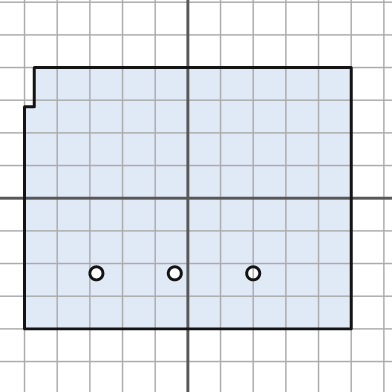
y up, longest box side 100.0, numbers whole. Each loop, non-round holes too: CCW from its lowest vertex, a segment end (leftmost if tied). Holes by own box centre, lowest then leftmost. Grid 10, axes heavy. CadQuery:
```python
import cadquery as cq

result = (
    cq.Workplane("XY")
    .moveTo(-50.0, -40.0)
    .lineTo(50.0, -40.0)
    .lineTo(50.0, 40.0)
    .lineTo(-47.0, 40.0)
    .lineTo(-47.0, 28.0)
    .lineTo(-50.0, 28.0)
    .close()
    .moveTo(-28.0, -23.0)
    .circle(2.0)
    .moveTo(-4.0, -23.0)
    .circle(2.0)
    .moveTo(20.0, -23.0)
    .circle(2.0)
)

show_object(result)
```